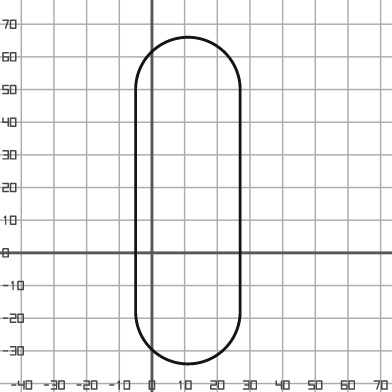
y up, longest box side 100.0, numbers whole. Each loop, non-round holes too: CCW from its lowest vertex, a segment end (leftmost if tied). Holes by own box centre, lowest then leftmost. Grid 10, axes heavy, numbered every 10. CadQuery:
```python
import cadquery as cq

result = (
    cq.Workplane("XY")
    .moveTo(-5.0, -18.0)
    .threePointArc((11.0, -34.0), (27.0, -18.0))
    .lineTo(27.0, 50.0)
    .threePointArc((11.0, 66.0), (-5.0, 50.0))
    .close()
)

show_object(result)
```